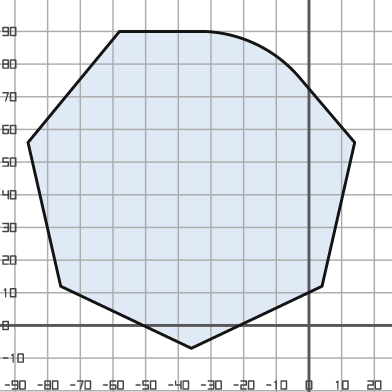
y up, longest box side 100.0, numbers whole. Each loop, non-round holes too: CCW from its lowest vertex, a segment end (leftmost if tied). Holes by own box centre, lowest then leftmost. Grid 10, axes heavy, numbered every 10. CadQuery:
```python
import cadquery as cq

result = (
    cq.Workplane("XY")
    .moveTo(-36.0, -7.0)
    .lineTo(4.0, 12.0)
    .lineTo(14.0, 56.0)
    .lineTo(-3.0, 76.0)
    .threePointArc((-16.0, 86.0), (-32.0, 90.0))
    .lineTo(-58.0, 90.0)
    .lineTo(-86.0, 56.0)
    .lineTo(-76.0, 12.0)
    .close()
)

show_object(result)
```